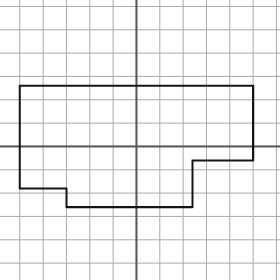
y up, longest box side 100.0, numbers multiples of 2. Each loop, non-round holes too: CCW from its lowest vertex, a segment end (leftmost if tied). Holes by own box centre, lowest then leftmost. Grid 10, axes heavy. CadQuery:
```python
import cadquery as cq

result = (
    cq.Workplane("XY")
    .moveTo(-30.0, -26.0)
    .lineTo(24.0, -26.0)
    .lineTo(24.0, -6.0)
    .lineTo(50.0, -6.0)
    .lineTo(50.0, 26.0)
    .lineTo(-50.0, 26.0)
    .lineTo(-50.0, -18.0)
    .lineTo(-30.0, -18.0)
    .close()
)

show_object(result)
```